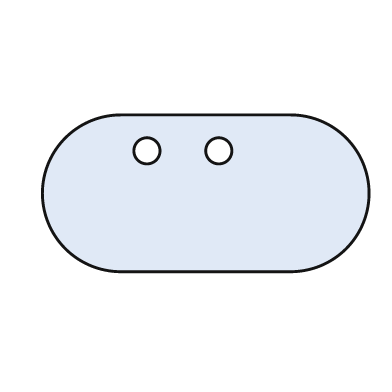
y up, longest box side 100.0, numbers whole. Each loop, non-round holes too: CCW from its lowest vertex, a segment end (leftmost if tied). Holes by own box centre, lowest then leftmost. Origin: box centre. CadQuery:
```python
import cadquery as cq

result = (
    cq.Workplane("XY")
    .moveTo(-26.0, -24.0)
    .lineTo(26.0, -24.0)
    .threePointArc((50.0, 0.0), (26.0, 24.0))
    .lineTo(-26.0, 24.0)
    .threePointArc((-50.0, 0.0), (-26.0, -24.0))
    .close()
    .moveTo(-18.0, 13.0)
    .circle(4.0)
    .moveTo(4.0, 13.0)
    .circle(4.0)
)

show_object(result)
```